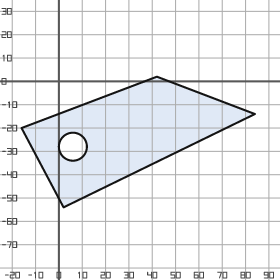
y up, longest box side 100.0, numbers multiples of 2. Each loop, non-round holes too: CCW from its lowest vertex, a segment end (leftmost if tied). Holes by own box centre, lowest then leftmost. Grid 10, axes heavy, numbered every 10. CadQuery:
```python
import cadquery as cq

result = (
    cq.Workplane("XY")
    .moveTo(2.0, -54.0)
    .lineTo(84.0, -14.0)
    .lineTo(42.0, 2.0)
    .lineTo(-16.0, -20.0)
    .close()
    .moveTo(6.0, -28.0)
    .circle(6.0)
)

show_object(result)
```